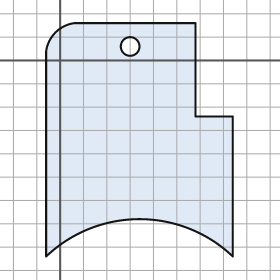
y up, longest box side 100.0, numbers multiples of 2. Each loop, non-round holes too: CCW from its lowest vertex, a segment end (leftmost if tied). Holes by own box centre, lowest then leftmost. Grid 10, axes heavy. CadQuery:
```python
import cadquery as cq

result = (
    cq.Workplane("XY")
    .moveTo(-6.0, -84.0)
    .threePointArc((34.0, -68.0), (74.0, -84.0))
    .lineTo(74.0, -24.0)
    .lineTo(58.0, -24.0)
    .lineTo(58.0, 16.0)
    .lineTo(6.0, 16.0)
    .threePointArc((-2.0, 12.0), (-6.0, 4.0))
    .close()
    .moveTo(30.0, 6.0)
    .circle(4.0)
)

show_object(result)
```